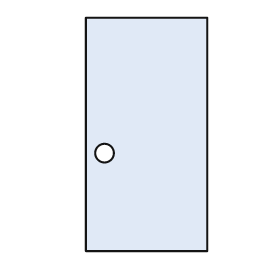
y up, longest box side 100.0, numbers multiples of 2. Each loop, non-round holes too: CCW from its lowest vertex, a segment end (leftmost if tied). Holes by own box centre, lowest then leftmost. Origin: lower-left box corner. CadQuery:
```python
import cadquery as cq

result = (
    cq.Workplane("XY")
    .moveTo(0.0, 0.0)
    .lineTo(52.0, 0.0)
    .lineTo(52.0, 100.0)
    .lineTo(0.0, 100.0)
    .close()
    .moveTo(8.0, 42.0)
    .circle(4.0)
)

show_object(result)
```